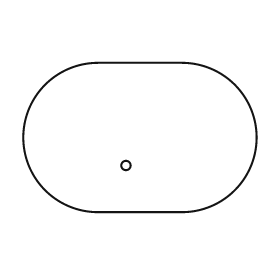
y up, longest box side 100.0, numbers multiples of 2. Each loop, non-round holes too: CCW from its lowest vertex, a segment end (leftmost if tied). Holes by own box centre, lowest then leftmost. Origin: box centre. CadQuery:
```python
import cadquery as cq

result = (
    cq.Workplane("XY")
    .moveTo(-18.0, -32.0)
    .lineTo(18.0, -32.0)
    .threePointArc((50.0, 0.0), (18.0, 32.0))
    .lineTo(-18.0, 32.0)
    .threePointArc((-50.0, 0.0), (-18.0, -32.0))
    .close()
    .moveTo(-6.0, -12.0)
    .circle(2.0)
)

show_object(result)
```